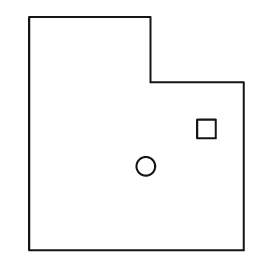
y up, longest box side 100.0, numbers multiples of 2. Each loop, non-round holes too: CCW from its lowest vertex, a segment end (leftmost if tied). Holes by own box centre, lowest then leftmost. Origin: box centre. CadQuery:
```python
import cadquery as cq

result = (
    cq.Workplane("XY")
    .moveTo(-46.0, -50.0)
    .lineTo(46.0, -50.0)
    .lineTo(46.0, 22.0)
    .lineTo(6.0, 22.0)
    .lineTo(6.0, 50.0)
    .lineTo(-46.0, 50.0)
    .close()
    .moveTo(4.0, -14.0)
    .circle(4.0)
    .moveTo(26.0, -2.0)
    .lineTo(34.0, -2.0)
    .lineTo(34.0, 6.0)
    .lineTo(26.0, 6.0)
    .close()
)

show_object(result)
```